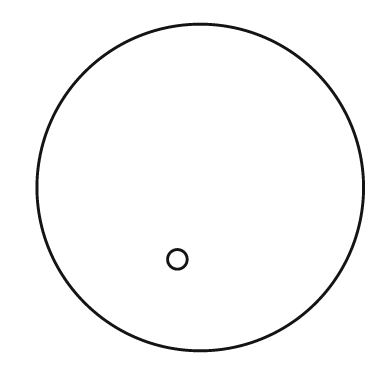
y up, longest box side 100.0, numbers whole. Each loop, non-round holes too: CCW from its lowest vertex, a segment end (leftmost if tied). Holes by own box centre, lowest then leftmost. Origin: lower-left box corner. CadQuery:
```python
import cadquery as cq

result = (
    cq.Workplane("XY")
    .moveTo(50.0, 50.0)
    .circle(50.0)
    .moveTo(43.0, 28.0)
    .circle(3.0)
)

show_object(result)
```